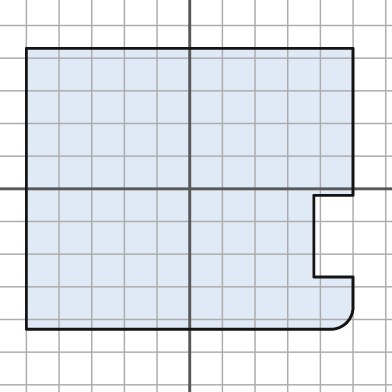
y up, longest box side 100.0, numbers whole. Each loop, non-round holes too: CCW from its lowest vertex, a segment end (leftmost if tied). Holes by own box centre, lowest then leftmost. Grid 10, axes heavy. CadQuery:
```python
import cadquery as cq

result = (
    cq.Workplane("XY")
    .moveTo(-50.0, -43.0)
    .lineTo(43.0, -43.0)
    .threePointArc((48.0, -41.0), (50.0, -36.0))
    .lineTo(50.0, -27.0)
    .lineTo(38.0, -27.0)
    .lineTo(38.0, -2.0)
    .lineTo(50.0, -2.0)
    .lineTo(50.0, 43.0)
    .lineTo(-50.0, 43.0)
    .close()
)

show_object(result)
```